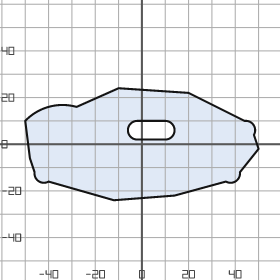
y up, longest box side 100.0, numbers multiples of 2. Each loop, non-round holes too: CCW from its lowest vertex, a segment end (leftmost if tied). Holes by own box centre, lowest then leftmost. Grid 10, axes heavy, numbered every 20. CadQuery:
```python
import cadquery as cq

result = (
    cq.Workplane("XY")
    .moveTo(-12.0, -24.0)
    .lineTo(14.0, -22.0)
    .lineTo(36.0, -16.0)
    .threePointArc((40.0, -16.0), (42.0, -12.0))
    .lineTo(50.0, -2.0)
    .lineTo(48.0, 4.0)
    .threePointArc((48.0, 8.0), (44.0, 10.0))
    .lineTo(20.0, 22.0)
    .lineTo(-10.0, 24.0)
    .lineTo(-28.0, 16.0)
    .threePointArc((-40.0, 16.0), (-50.0, 10.0))
    .lineTo(-48.0, -6.0)
    .lineTo(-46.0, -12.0)
    .threePointArc((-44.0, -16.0), (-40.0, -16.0))
    .close()
    .moveTo(-2.0, 2.0)
    .lineTo(10.0, 2.0)
    .threePointArc((14.0, 6.0), (10.0, 10.0))
    .lineTo(-2.0, 10.0)
    .threePointArc((-6.0, 6.0), (-2.0, 2.0))
    .close()
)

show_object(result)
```